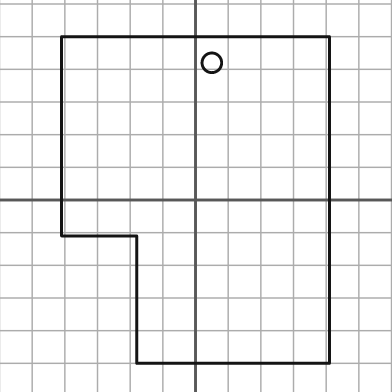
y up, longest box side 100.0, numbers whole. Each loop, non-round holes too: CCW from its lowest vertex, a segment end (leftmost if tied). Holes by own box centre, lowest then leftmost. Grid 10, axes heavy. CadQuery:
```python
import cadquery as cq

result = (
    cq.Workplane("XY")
    .moveTo(-18.0, -50.0)
    .lineTo(41.0, -50.0)
    .lineTo(41.0, 50.0)
    .lineTo(-41.0, 50.0)
    .lineTo(-41.0, -11.0)
    .lineTo(-18.0, -11.0)
    .close()
    .moveTo(5.0, 42.0)
    .circle(3.0)
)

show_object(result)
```